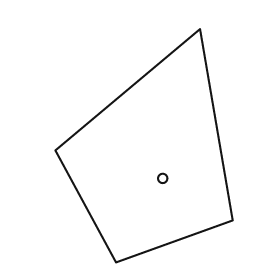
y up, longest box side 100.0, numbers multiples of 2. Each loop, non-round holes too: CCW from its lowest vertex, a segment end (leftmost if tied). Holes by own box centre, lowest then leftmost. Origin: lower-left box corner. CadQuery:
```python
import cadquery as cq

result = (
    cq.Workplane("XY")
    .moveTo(26.0, 0.0)
    .lineTo(76.0, 18.0)
    .lineTo(62.0, 100.0)
    .lineTo(0.0, 48.0)
    .close()
    .moveTo(46.0, 36.0)
    .circle(2.0)
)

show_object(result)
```